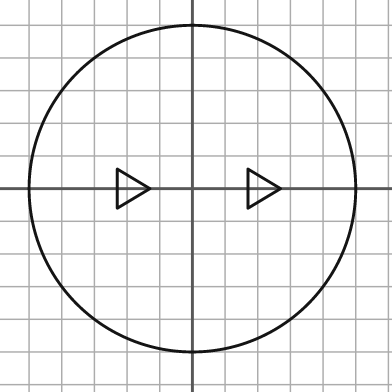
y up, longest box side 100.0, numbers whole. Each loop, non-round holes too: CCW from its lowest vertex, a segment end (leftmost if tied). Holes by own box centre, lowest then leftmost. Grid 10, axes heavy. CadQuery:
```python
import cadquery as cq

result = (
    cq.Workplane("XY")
    .moveTo(0.0, 0.0)
    .circle(50.0)
    .moveTo(-23.0, -6.0)
    .lineTo(-13.0, 0.0)
    .lineTo(-23.0, 6.0)
    .close()
    .moveTo(17.0, -6.0)
    .lineTo(27.0, 0.0)
    .lineTo(17.0, 6.0)
    .close()
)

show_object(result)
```